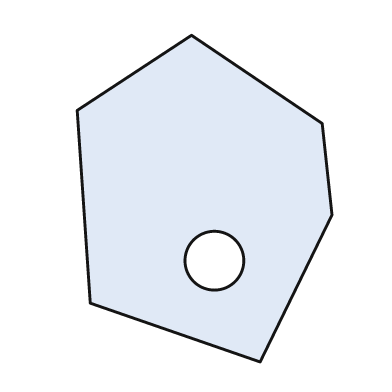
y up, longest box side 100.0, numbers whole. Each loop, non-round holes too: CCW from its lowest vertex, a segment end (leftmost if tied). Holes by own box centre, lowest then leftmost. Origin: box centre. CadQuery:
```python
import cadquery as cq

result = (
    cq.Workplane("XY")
    .moveTo(17.0, -50.0)
    .lineTo(39.0, -5.0)
    .lineTo(36.0, 23.0)
    .lineTo(-4.0, 50.0)
    .lineTo(-39.0, 27.0)
    .lineTo(-35.0, -32.0)
    .close()
    .moveTo(3.0, -19.0)
    .circle(9.0)
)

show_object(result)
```